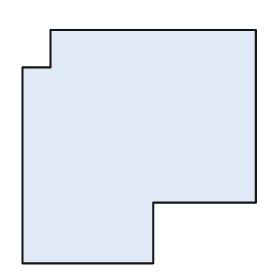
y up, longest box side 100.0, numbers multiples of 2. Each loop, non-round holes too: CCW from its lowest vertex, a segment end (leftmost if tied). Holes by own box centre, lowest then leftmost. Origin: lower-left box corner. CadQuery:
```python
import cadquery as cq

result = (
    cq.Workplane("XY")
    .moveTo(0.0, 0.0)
    .lineTo(56.0, 0.0)
    .lineTo(56.0, 26.0)
    .lineTo(100.0, 26.0)
    .lineTo(100.0, 100.0)
    .lineTo(12.0, 100.0)
    .lineTo(12.0, 84.0)
    .lineTo(0.0, 84.0)
    .close()
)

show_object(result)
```